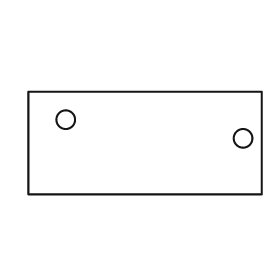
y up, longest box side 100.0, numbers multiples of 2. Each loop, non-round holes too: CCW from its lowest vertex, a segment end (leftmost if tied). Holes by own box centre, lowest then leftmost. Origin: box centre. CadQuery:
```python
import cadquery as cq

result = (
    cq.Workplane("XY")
    .moveTo(-50.0, -22.0)
    .lineTo(50.0, -22.0)
    .lineTo(50.0, 22.0)
    .lineTo(-50.0, 22.0)
    .close()
    .moveTo(42.0, 2.0)
    .circle(4.0)
    .moveTo(-34.0, 10.0)
    .circle(4.0)
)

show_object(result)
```